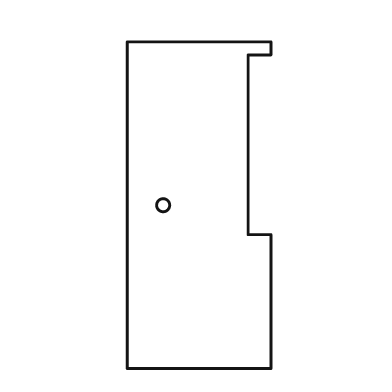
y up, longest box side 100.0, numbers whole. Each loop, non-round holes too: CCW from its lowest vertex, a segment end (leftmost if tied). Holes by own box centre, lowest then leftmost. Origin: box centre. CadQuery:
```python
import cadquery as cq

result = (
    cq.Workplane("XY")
    .moveTo(-22.0, -50.0)
    .lineTo(22.0, -50.0)
    .lineTo(22.0, -9.0)
    .lineTo(15.0, -9.0)
    .lineTo(15.0, 46.0)
    .lineTo(22.0, 46.0)
    .lineTo(22.0, 50.0)
    .lineTo(-22.0, 50.0)
    .close()
    .moveTo(-11.0, 0.0)
    .circle(2.0)
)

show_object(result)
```